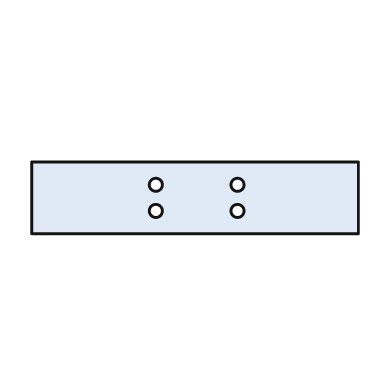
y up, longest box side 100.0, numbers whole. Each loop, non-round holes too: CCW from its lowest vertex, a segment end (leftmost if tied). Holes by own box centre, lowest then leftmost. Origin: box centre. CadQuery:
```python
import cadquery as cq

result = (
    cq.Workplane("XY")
    .moveTo(-50.0, -11.0)
    .lineTo(50.0, -11.0)
    .lineTo(50.0, 11.0)
    .lineTo(-50.0, 11.0)
    .close()
    .moveTo(-12.0, -4.0)
    .circle(2.0)
    .moveTo(13.0, -4.0)
    .circle(2.0)
    .moveTo(-12.0, 4.0)
    .circle(2.0)
    .moveTo(13.0, 4.0)
    .circle(2.0)
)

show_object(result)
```